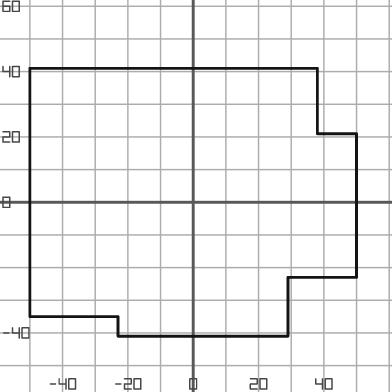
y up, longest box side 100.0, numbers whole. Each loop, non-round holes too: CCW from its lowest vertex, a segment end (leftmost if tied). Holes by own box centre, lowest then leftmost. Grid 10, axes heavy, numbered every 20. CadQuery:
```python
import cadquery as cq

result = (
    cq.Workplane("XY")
    .moveTo(-23.0, -41.0)
    .lineTo(29.0, -41.0)
    .lineTo(29.0, -23.0)
    .lineTo(50.0, -23.0)
    .lineTo(50.0, 21.0)
    .lineTo(38.0, 21.0)
    .lineTo(38.0, 41.0)
    .lineTo(-50.0, 41.0)
    .lineTo(-50.0, -35.0)
    .lineTo(-23.0, -35.0)
    .close()
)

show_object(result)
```